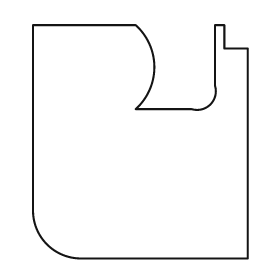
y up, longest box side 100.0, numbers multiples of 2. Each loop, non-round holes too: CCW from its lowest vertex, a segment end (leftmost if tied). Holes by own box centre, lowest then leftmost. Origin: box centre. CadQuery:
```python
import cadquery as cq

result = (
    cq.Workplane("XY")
    .moveTo(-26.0, -50.0)
    .lineTo(46.0, -50.0)
    .lineTo(46.0, 40.0)
    .lineTo(36.0, 40.0)
    .lineTo(36.0, 50.0)
    .lineTo(32.0, 50.0)
    .lineTo(32.0, 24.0)
    .threePointArc((30.0, 16.0), (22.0, 14.0))
    .lineTo(-2.0, 14.0)
    .threePointArc((6.0, 32.0), (-2.0, 50.0))
    .lineTo(-46.0, 50.0)
    .lineTo(-46.0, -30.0)
    .threePointArc((-40.0, -44.0), (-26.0, -50.0))
    .close()
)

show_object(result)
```